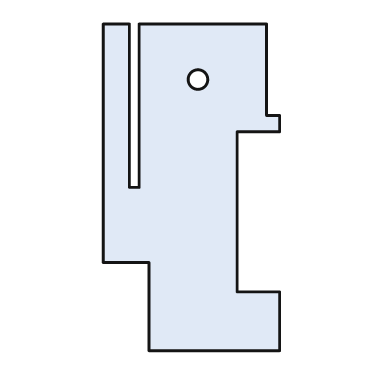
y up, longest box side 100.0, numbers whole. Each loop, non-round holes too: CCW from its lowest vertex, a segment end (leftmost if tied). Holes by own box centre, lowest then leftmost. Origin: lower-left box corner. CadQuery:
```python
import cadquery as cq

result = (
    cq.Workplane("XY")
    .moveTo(14.0, 0.0)
    .lineTo(54.0, 0.0)
    .lineTo(54.0, 18.0)
    .lineTo(41.0, 18.0)
    .lineTo(41.0, 67.0)
    .lineTo(54.0, 67.0)
    .lineTo(54.0, 72.0)
    .lineTo(50.0, 72.0)
    .lineTo(50.0, 100.0)
    .lineTo(11.0, 100.0)
    .lineTo(11.0, 50.0)
    .lineTo(8.0, 50.0)
    .lineTo(8.0, 100.0)
    .lineTo(0.0, 100.0)
    .lineTo(0.0, 27.0)
    .lineTo(14.0, 27.0)
    .close()
    .moveTo(29.0, 83.0)
    .circle(3.0)
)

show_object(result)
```